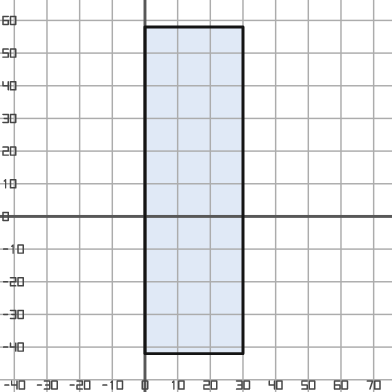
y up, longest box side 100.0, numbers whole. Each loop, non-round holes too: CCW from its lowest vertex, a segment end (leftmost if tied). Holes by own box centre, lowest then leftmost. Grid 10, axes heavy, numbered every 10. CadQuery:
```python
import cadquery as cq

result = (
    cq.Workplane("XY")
    .moveTo(0.0, -42.0)
    .lineTo(30.0, -42.0)
    .lineTo(30.0, 58.0)
    .lineTo(0.0, 58.0)
    .close()
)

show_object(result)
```